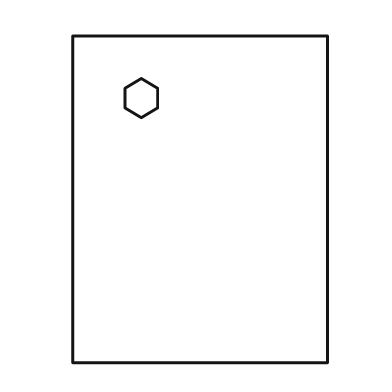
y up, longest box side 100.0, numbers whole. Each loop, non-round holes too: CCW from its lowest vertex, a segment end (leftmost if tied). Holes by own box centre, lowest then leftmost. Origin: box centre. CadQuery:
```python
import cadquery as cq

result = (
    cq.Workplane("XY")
    .moveTo(-39.0, -50.0)
    .lineTo(39.0, -50.0)
    .lineTo(39.0, 50.0)
    .lineTo(-39.0, 50.0)
    .close()
    .moveTo(-18.0, 25.0)
    .lineTo(-13.0, 28.0)
    .lineTo(-13.0, 34.0)
    .lineTo(-18.0, 37.0)
    .lineTo(-23.0, 34.0)
    .lineTo(-23.0, 28.0)
    .close()
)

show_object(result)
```